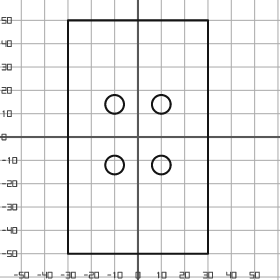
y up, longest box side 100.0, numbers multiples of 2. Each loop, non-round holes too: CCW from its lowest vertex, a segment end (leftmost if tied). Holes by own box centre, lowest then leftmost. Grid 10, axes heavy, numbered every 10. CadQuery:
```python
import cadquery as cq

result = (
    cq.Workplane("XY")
    .moveTo(-30.0, -50.0)
    .lineTo(30.0, -50.0)
    .lineTo(30.0, 50.0)
    .lineTo(-30.0, 50.0)
    .close()
    .moveTo(-10.0, -12.0)
    .circle(4.0)
    .moveTo(10.0, -12.0)
    .circle(4.0)
    .moveTo(-10.0, 14.0)
    .circle(4.0)
    .moveTo(10.0, 14.0)
    .circle(4.0)
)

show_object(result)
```